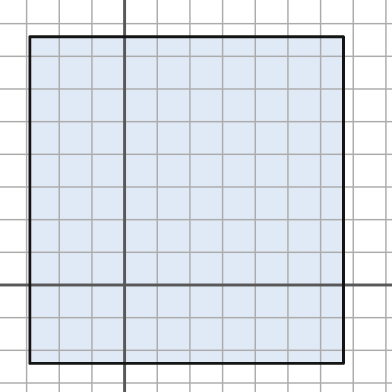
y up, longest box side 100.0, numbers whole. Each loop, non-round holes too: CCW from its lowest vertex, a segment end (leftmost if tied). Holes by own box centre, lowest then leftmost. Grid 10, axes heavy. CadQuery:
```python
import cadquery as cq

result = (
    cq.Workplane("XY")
    .moveTo(-29.0, -24.0)
    .lineTo(67.0, -24.0)
    .lineTo(67.0, 76.0)
    .lineTo(-29.0, 76.0)
    .close()
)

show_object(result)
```